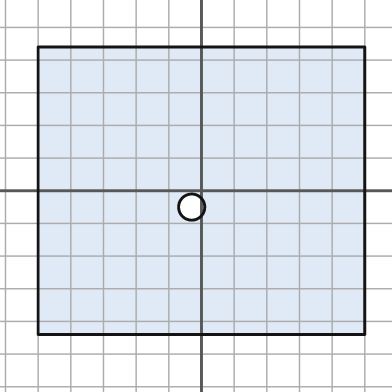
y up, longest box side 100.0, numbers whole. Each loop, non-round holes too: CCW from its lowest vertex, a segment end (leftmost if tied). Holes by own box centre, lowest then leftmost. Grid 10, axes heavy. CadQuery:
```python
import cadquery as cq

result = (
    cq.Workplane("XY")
    .moveTo(-50.0, -44.0)
    .lineTo(50.0, -44.0)
    .lineTo(50.0, 44.0)
    .lineTo(-50.0, 44.0)
    .close()
    .moveTo(-3.0, -5.0)
    .circle(4.0)
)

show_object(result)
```